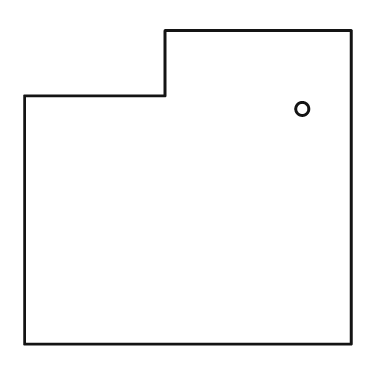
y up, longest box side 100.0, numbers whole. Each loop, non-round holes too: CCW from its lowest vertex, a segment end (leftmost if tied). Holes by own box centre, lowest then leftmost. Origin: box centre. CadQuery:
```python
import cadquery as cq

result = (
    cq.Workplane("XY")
    .moveTo(-50.0, -48.0)
    .lineTo(50.0, -48.0)
    .lineTo(50.0, 48.0)
    .lineTo(-7.0, 48.0)
    .lineTo(-7.0, 28.0)
    .lineTo(-50.0, 28.0)
    .close()
    .moveTo(35.0, 24.0)
    .circle(2.0)
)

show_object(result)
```